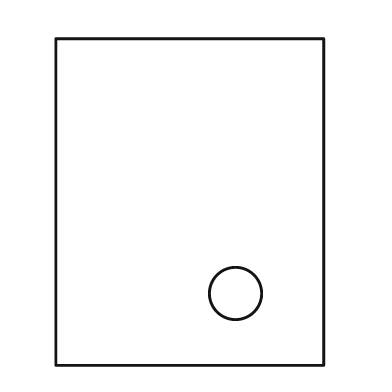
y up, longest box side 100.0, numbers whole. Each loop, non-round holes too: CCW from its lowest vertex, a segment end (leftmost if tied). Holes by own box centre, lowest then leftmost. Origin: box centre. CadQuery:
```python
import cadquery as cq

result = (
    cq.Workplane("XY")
    .moveTo(-41.0, -50.0)
    .lineTo(41.0, -50.0)
    .lineTo(41.0, 50.0)
    .lineTo(-41.0, 50.0)
    .close()
    .moveTo(14.0, -28.0)
    .circle(8.0)
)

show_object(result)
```